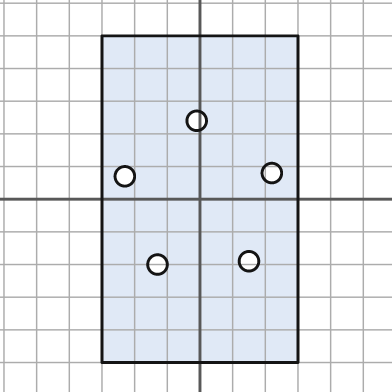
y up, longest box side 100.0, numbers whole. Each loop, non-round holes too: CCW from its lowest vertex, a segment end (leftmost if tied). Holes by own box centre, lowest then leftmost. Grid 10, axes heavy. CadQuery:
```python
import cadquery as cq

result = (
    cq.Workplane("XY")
    .moveTo(-30.0, -50.0)
    .lineTo(30.0, -50.0)
    .lineTo(30.0, 50.0)
    .lineTo(-30.0, 50.0)
    .close()
    .moveTo(-13.0, -20.0)
    .circle(3.0)
    .moveTo(15.0, -19.0)
    .circle(3.0)
    .moveTo(-23.0, 7.0)
    .circle(3.0)
    .moveTo(22.0, 8.0)
    .circle(3.0)
    .moveTo(-1.0, 24.0)
    .circle(3.0)
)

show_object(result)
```